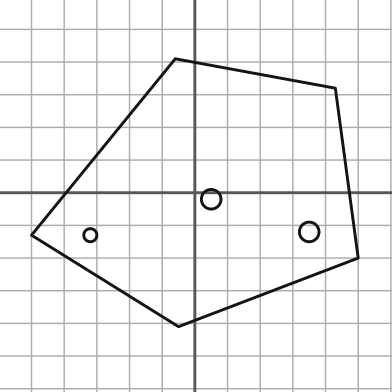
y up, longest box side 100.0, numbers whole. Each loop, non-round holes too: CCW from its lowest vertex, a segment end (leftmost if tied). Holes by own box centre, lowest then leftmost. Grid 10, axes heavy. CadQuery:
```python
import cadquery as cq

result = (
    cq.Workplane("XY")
    .moveTo(-5.0, -41.0)
    .lineTo(50.0, -20.0)
    .lineTo(43.0, 32.0)
    .lineTo(-6.0, 41.0)
    .lineTo(-50.0, -13.0)
    .close()
    .moveTo(-32.0, -13.0)
    .circle(2.0)
    .moveTo(35.0, -12.0)
    .circle(3.0)
    .moveTo(5.0, -2.0)
    .circle(3.0)
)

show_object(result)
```